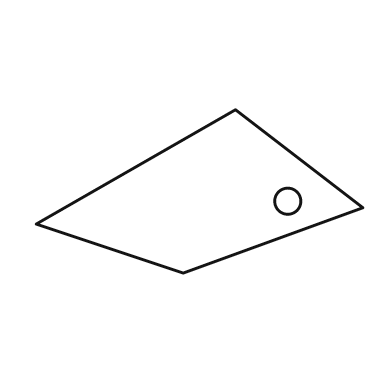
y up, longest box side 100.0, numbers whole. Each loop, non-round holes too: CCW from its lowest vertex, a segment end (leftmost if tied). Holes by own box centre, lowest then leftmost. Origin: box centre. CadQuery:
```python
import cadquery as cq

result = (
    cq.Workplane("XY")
    .moveTo(-5.0, -25.0)
    .lineTo(50.0, -5.0)
    .lineTo(11.0, 25.0)
    .lineTo(-50.0, -10.0)
    .close()
    .moveTo(27.0, -3.0)
    .circle(4.0)
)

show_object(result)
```